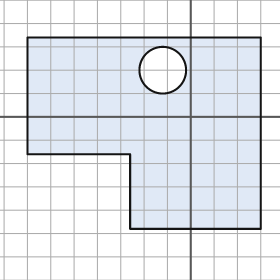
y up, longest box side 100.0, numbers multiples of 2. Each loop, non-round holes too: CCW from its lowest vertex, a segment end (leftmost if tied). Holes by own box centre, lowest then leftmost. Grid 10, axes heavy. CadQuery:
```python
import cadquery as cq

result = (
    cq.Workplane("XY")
    .moveTo(-26.0, -48.0)
    .lineTo(30.0, -48.0)
    .lineTo(30.0, 34.0)
    .lineTo(-70.0, 34.0)
    .lineTo(-70.0, -16.0)
    .lineTo(-26.0, -16.0)
    .close()
    .moveTo(-12.0, 20.0)
    .circle(10.0)
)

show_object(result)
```